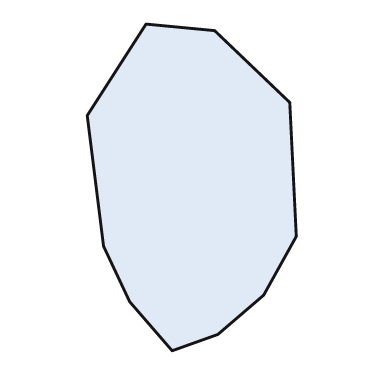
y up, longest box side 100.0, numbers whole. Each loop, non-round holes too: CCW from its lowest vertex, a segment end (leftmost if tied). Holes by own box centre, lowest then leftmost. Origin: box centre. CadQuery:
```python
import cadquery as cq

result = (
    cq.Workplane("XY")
    .moveTo(-6.0, -50.0)
    .lineTo(8.0, -45.0)
    .lineTo(22.0, -33.0)
    .lineTo(32.0, -15.0)
    .lineTo(30.0, 26.0)
    .lineTo(7.0, 48.0)
    .lineTo(-14.0, 50.0)
    .lineTo(-32.0, 22.0)
    .lineTo(-27.0, -18.0)
    .lineTo(-19.0, -35.0)
    .close()
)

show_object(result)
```